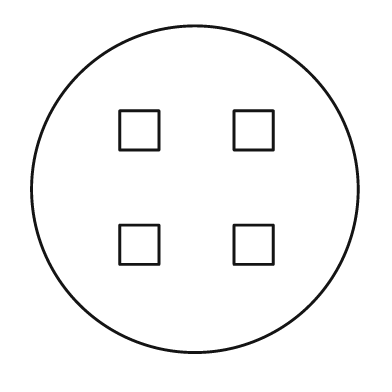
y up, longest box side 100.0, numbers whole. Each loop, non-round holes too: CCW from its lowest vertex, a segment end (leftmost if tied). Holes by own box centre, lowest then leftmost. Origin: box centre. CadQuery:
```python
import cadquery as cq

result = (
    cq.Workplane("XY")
    .moveTo(0.0, 0.0)
    .circle(50.0)
    .moveTo(-23.0, -23.0)
    .lineTo(-11.0, -23.0)
    .lineTo(-11.0, -11.0)
    .lineTo(-23.0, -11.0)
    .close()
    .moveTo(12.0, -23.0)
    .lineTo(24.0, -23.0)
    .lineTo(24.0, -11.0)
    .lineTo(12.0, -11.0)
    .close()
    .moveTo(-23.0, 12.0)
    .lineTo(-11.0, 12.0)
    .lineTo(-11.0, 24.0)
    .lineTo(-23.0, 24.0)
    .close()
    .moveTo(12.0, 12.0)
    .lineTo(24.0, 12.0)
    .lineTo(24.0, 24.0)
    .lineTo(12.0, 24.0)
    .close()
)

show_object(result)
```